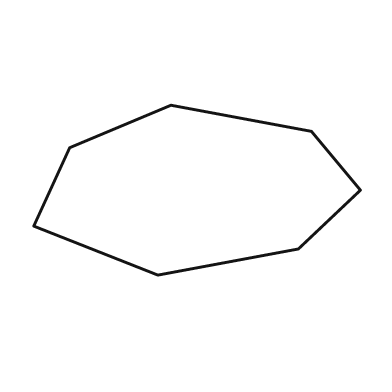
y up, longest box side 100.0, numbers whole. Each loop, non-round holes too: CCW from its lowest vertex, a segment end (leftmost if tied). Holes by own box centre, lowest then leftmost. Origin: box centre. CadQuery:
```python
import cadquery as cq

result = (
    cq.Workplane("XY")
    .moveTo(-12.0, -26.0)
    .lineTo(31.0, -18.0)
    .lineTo(50.0, 0.0)
    .lineTo(35.0, 18.0)
    .lineTo(-8.0, 26.0)
    .lineTo(-39.0, 13.0)
    .lineTo(-50.0, -11.0)
    .close()
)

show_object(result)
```